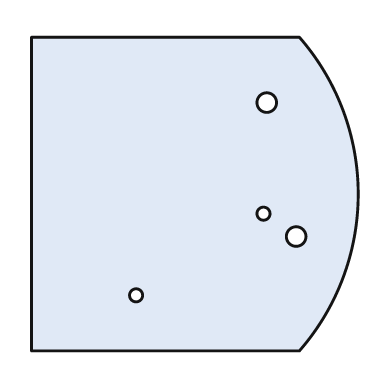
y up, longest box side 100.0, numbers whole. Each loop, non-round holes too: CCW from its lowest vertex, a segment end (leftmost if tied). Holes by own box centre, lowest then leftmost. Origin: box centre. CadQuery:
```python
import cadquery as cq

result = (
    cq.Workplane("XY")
    .moveTo(-50.0, -48.0)
    .lineTo(32.0, -48.0)
    .threePointArc((50.0, 0.0), (32.0, 48.0))
    .lineTo(-50.0, 48.0)
    .close()
    .moveTo(-18.0, -31.0)
    .circle(2.0)
    .moveTo(31.0, -13.0)
    .circle(3.0)
    .moveTo(21.0, -6.0)
    .circle(2.0)
    .moveTo(22.0, 28.0)
    .circle(3.0)
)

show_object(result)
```